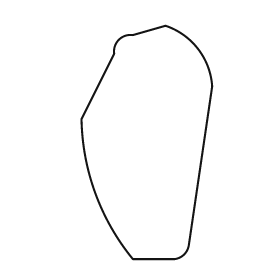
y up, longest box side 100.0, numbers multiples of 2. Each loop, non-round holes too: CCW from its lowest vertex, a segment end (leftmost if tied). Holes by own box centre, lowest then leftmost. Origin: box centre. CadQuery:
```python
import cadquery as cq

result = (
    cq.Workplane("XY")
    .moveTo(-6.0, -50.0)
    .lineTo(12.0, -50.0)
    .threePointArc((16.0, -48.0), (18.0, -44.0))
    .lineTo(28.0, 24.0)
    .threePointArc((22.0, 40.0), (8.0, 50.0))
    .lineTo(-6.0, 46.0)
    .threePointArc((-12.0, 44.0), (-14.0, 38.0))
    .lineTo(-28.0, 10.0)
    .threePointArc((-22.0, -22.0), (-6.0, -50.0))
    .close()
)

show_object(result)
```